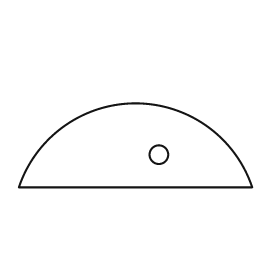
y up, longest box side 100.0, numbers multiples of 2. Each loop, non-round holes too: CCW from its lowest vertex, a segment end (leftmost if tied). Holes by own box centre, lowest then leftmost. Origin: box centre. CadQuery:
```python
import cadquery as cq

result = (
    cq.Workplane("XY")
    .moveTo(-50.0, -18.0)
    .lineTo(50.0, -18.0)
    .threePointArc((0.0, 18.0), (-50.0, -18.0))
    .close()
    .moveTo(10.0, -4.0)
    .circle(4.0)
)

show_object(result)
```